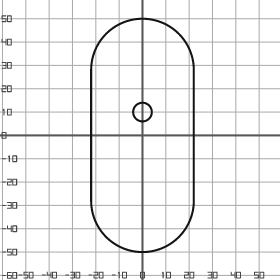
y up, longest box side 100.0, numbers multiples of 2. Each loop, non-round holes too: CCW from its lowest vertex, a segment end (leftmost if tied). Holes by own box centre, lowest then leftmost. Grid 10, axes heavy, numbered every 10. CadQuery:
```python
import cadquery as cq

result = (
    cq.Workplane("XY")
    .moveTo(-22.0, -28.0)
    .threePointArc((0.0, -50.0), (22.0, -28.0))
    .lineTo(22.0, 28.0)
    .threePointArc((0.0, 50.0), (-22.0, 28.0))
    .close()
    .moveTo(0.0, 10.0)
    .circle(4.0)
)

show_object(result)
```